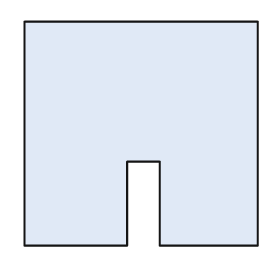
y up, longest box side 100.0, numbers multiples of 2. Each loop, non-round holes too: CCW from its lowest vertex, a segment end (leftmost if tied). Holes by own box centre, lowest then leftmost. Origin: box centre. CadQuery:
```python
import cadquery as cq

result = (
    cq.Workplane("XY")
    .moveTo(-50.0, -48.0)
    .lineTo(-6.0, -48.0)
    .lineTo(-6.0, -12.0)
    .lineTo(8.0, -12.0)
    .lineTo(8.0, -48.0)
    .lineTo(50.0, -48.0)
    .lineTo(50.0, 48.0)
    .lineTo(-50.0, 48.0)
    .close()
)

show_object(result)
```